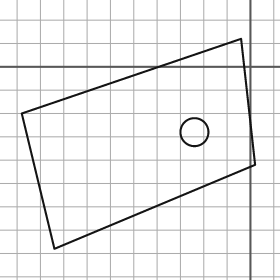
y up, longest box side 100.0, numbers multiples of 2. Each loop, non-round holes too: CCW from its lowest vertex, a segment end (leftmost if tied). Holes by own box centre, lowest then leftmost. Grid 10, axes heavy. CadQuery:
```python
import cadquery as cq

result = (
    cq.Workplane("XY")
    .moveTo(-84.0, -78.0)
    .lineTo(2.0, -42.0)
    .lineTo(-4.0, 12.0)
    .lineTo(-98.0, -20.0)
    .close()
    .moveTo(-24.0, -28.0)
    .circle(6.0)
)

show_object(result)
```